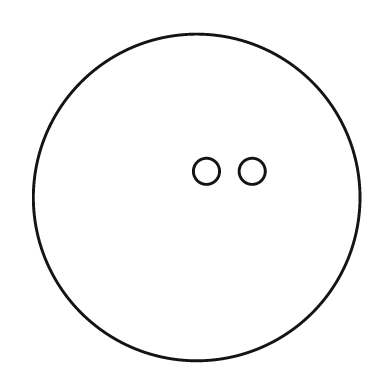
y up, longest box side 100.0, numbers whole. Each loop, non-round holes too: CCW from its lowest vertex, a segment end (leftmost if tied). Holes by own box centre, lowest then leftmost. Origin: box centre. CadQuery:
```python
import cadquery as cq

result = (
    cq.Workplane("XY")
    .moveTo(0.0, 0.0)
    .circle(50.0)
    .moveTo(3.0, 8.0)
    .circle(4.0)
    .moveTo(17.0, 8.0)
    .circle(4.0)
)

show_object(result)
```